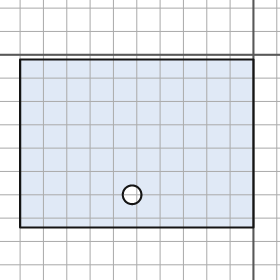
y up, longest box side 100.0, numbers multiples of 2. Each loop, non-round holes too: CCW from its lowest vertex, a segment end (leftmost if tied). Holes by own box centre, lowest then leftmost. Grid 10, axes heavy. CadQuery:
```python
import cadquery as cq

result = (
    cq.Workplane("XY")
    .moveTo(-100.0, -74.0)
    .lineTo(0.0, -74.0)
    .lineTo(0.0, -2.0)
    .lineTo(-100.0, -2.0)
    .close()
    .moveTo(-52.0, -60.0)
    .circle(4.0)
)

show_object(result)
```